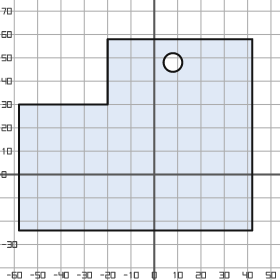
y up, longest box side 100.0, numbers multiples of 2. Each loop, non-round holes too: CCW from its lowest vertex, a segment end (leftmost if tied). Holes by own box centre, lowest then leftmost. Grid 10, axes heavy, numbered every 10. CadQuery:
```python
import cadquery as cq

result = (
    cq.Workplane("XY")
    .moveTo(-58.0, -24.0)
    .lineTo(42.0, -24.0)
    .lineTo(42.0, 58.0)
    .lineTo(-20.0, 58.0)
    .lineTo(-20.0, 30.0)
    .lineTo(-58.0, 30.0)
    .close()
    .moveTo(8.0, 48.0)
    .circle(4.0)
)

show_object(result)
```